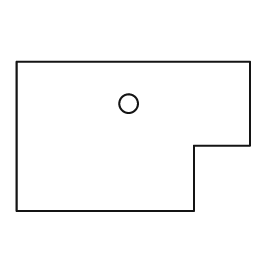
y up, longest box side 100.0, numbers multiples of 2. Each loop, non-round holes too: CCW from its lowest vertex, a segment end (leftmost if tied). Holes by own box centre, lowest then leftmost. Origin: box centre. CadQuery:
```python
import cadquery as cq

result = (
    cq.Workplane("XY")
    .moveTo(-50.0, -32.0)
    .lineTo(26.0, -32.0)
    .lineTo(26.0, -4.0)
    .lineTo(50.0, -4.0)
    .lineTo(50.0, 32.0)
    .lineTo(-50.0, 32.0)
    .close()
    .moveTo(-2.0, 14.0)
    .circle(4.0)
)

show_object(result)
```